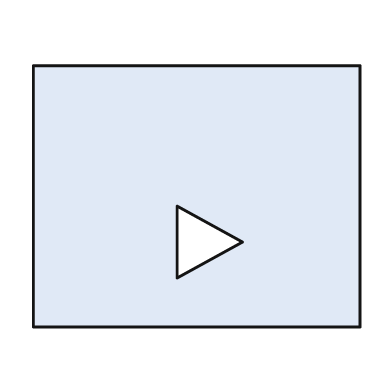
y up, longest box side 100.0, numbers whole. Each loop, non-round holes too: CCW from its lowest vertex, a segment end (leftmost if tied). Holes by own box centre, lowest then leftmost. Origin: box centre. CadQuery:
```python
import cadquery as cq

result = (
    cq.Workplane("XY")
    .moveTo(-50.0, -40.0)
    .lineTo(50.0, -40.0)
    .lineTo(50.0, 40.0)
    .lineTo(-50.0, 40.0)
    .close()
    .moveTo(-6.0, -25.0)
    .lineTo(14.0, -14.0)
    .lineTo(-6.0, -3.0)
    .close()
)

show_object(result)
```